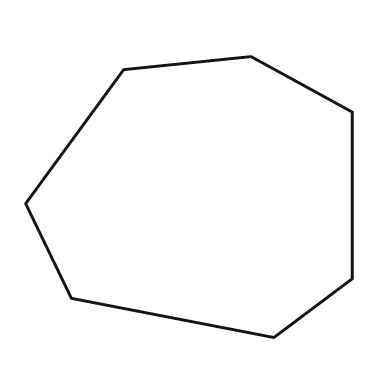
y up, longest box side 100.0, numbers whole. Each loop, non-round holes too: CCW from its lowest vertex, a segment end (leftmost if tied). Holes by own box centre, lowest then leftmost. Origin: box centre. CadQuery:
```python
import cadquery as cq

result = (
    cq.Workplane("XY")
    .moveTo(26.0, -43.0)
    .lineTo(50.0, -25.0)
    .lineTo(50.0, 26.0)
    .lineTo(19.0, 43.0)
    .lineTo(-20.0, 39.0)
    .lineTo(-50.0, -2.0)
    .lineTo(-36.0, -31.0)
    .close()
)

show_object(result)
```